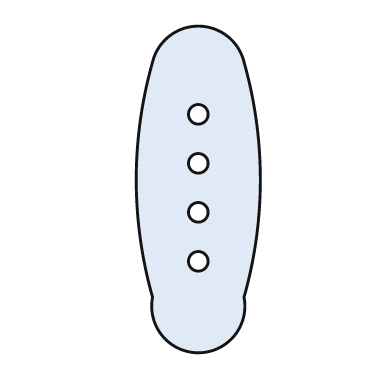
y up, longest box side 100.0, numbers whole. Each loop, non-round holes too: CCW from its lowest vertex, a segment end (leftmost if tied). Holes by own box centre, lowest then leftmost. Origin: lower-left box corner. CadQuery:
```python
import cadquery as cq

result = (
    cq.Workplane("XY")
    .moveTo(5.0, 17.0)
    .threePointArc((19.0, 0.0), (33.0, 17.0))
    .threePointArc((38.0, 53.0), (33.0, 89.0))
    .threePointArc((19.0, 100.0), (5.0, 89.0))
    .threePointArc((0.0, 53.0), (5.0, 17.0))
    .close()
    .moveTo(19.0, 28.0)
    .circle(3.0)
    .moveTo(19.0, 43.0)
    .circle(3.0)
    .moveTo(19.0, 58.0)
    .circle(3.0)
    .moveTo(19.0, 73.0)
    .circle(3.0)
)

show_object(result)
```